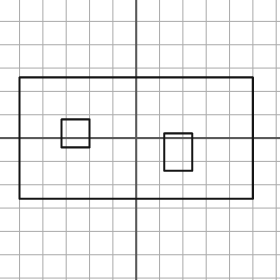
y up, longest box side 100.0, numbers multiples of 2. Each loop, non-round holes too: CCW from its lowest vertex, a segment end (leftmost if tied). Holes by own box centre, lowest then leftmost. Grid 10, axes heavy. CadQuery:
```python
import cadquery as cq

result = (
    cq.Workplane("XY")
    .moveTo(-50.0, -26.0)
    .lineTo(50.0, -26.0)
    .lineTo(50.0, 26.0)
    .lineTo(-50.0, 26.0)
    .close()
    .moveTo(12.0, -14.0)
    .lineTo(24.0, -14.0)
    .lineTo(24.0, 2.0)
    .lineTo(12.0, 2.0)
    .close()
    .moveTo(-32.0, -4.0)
    .lineTo(-20.0, -4.0)
    .lineTo(-20.0, 8.0)
    .lineTo(-32.0, 8.0)
    .close()
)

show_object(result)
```